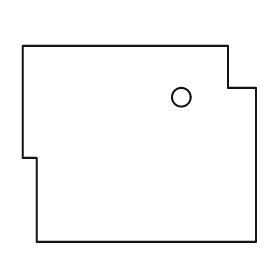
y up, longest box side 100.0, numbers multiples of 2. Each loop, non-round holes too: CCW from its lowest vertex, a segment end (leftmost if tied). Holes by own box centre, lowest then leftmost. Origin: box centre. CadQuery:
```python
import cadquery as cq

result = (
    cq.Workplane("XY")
    .moveTo(-44.0, -42.0)
    .lineTo(50.0, -42.0)
    .lineTo(50.0, 24.0)
    .lineTo(38.0, 24.0)
    .lineTo(38.0, 42.0)
    .lineTo(-50.0, 42.0)
    .lineTo(-50.0, -6.0)
    .lineTo(-44.0, -6.0)
    .close()
    .moveTo(18.0, 20.0)
    .circle(4.0)
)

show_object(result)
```